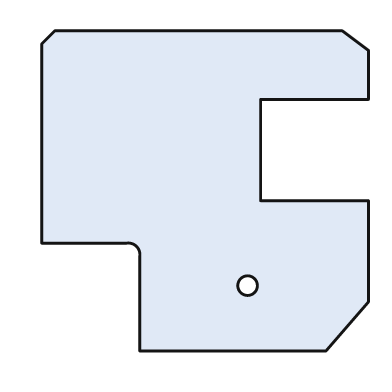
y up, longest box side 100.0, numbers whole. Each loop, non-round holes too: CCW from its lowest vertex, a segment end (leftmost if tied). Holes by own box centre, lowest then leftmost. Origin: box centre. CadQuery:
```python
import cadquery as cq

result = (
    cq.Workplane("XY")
    .moveTo(-20.0, -49.0)
    .lineTo(37.0, -49.0)
    .lineTo(50.0, -34.0)
    .lineTo(50.0, -3.0)
    .lineTo(17.0, -3.0)
    .lineTo(17.0, 28.0)
    .lineTo(50.0, 28.0)
    .lineTo(50.0, 43.0)
    .lineTo(42.0, 49.0)
    .lineTo(-46.0, 49.0)
    .lineTo(-50.0, 45.0)
    .lineTo(-50.0, -16.0)
    .lineTo(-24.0, -16.0)
    .threePointArc((-21.0, -17.0), (-20.0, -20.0))
    .close()
    .moveTo(13.0, -29.0)
    .circle(3.0)
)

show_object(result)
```